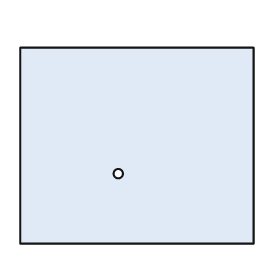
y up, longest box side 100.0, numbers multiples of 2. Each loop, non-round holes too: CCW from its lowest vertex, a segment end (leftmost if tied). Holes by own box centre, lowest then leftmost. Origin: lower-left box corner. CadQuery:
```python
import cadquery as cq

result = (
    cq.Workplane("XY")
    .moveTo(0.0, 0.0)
    .lineTo(100.0, 0.0)
    .lineTo(100.0, 84.0)
    .lineTo(0.0, 84.0)
    .close()
    .moveTo(42.0, 30.0)
    .circle(2.0)
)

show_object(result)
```